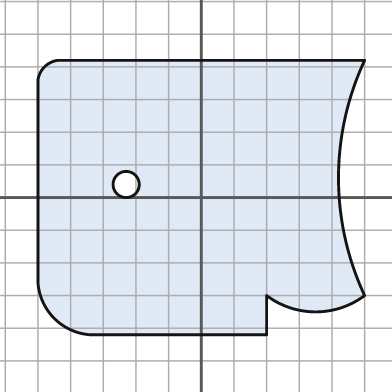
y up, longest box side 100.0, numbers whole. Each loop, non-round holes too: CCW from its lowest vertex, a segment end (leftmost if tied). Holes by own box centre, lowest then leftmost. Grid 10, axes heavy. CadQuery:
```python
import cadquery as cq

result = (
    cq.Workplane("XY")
    .moveTo(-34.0, -42.0)
    .lineTo(20.0, -42.0)
    .lineTo(20.0, -30.0)
    .threePointArc((35.0, -35.0), (50.0, -30.0))
    .threePointArc((42.0, 6.0), (50.0, 42.0))
    .lineTo(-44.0, 42.0)
    .threePointArc((-48.0, 40.0), (-50.0, 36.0))
    .lineTo(-50.0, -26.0)
    .threePointArc((-45.0, -37.0), (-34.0, -42.0))
    .close()
    .moveTo(-23.0, 4.0)
    .circle(4.0)
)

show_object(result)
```